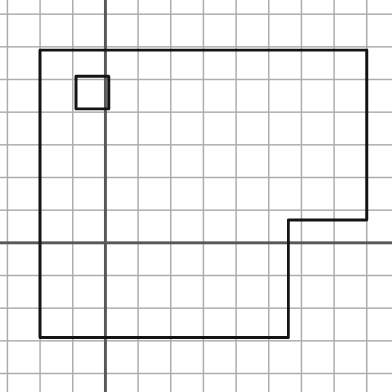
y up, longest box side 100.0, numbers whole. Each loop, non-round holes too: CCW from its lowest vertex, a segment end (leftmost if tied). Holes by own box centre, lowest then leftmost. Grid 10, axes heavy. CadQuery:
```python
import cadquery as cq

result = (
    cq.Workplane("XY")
    .moveTo(-20.0, -29.0)
    .lineTo(56.0, -29.0)
    .lineTo(56.0, 7.0)
    .lineTo(80.0, 7.0)
    .lineTo(80.0, 59.0)
    .lineTo(-20.0, 59.0)
    .close()
    .moveTo(-9.0, 41.0)
    .lineTo(1.0, 41.0)
    .lineTo(1.0, 51.0)
    .lineTo(-9.0, 51.0)
    .close()
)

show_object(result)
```